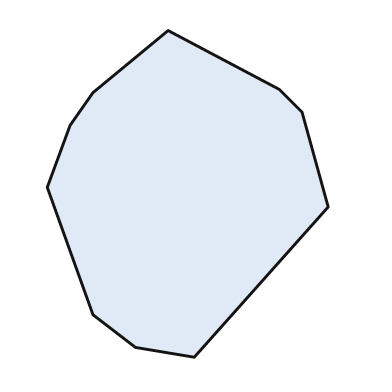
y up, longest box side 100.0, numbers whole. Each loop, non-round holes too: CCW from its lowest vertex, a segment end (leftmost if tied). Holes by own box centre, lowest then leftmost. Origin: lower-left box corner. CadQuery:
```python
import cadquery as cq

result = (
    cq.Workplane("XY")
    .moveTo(45.0, 0.0)
    .lineTo(86.0, 46.0)
    .lineTo(78.0, 75.0)
    .lineTo(71.0, 82.0)
    .lineTo(37.0, 100.0)
    .lineTo(14.0, 81.0)
    .lineTo(7.0, 71.0)
    .lineTo(0.0, 52.0)
    .lineTo(14.0, 13.0)
    .lineTo(27.0, 3.0)
    .close()
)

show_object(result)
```